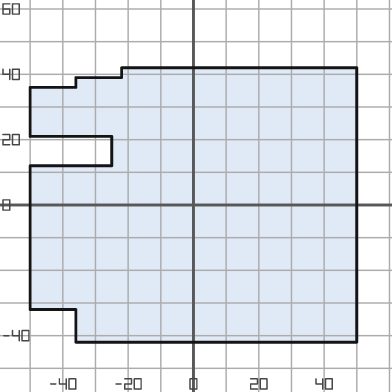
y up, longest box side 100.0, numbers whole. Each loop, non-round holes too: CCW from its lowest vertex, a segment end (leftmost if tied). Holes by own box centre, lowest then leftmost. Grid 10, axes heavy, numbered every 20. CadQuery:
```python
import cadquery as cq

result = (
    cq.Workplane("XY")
    .moveTo(-36.0, -42.0)
    .lineTo(50.0, -42.0)
    .lineTo(50.0, 42.0)
    .lineTo(-22.0, 42.0)
    .lineTo(-22.0, 39.0)
    .lineTo(-36.0, 39.0)
    .lineTo(-36.0, 36.0)
    .lineTo(-50.0, 36.0)
    .lineTo(-50.0, 21.0)
    .lineTo(-25.0, 21.0)
    .lineTo(-25.0, 12.0)
    .lineTo(-50.0, 12.0)
    .lineTo(-50.0, -32.0)
    .lineTo(-36.0, -32.0)
    .close()
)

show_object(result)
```